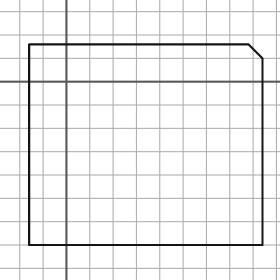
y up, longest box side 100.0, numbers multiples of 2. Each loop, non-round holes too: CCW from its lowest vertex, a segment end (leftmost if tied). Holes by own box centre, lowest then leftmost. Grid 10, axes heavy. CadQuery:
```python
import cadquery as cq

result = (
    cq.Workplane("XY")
    .moveTo(-16.0, -70.0)
    .lineTo(84.0, -70.0)
    .lineTo(84.0, 10.0)
    .lineTo(78.0, 16.0)
    .lineTo(-16.0, 16.0)
    .close()
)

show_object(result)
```